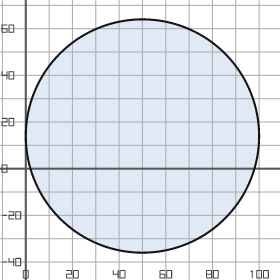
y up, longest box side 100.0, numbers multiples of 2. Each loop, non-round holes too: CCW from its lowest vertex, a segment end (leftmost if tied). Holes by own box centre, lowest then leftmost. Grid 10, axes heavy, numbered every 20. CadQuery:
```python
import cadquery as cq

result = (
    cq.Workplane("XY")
    .moveTo(50.0, 14.0)
    .circle(50.0)
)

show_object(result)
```